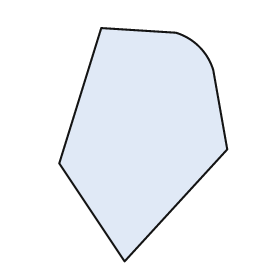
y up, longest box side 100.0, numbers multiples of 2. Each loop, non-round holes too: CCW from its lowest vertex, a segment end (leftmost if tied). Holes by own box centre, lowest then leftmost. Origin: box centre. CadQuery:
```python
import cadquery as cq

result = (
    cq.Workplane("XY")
    .moveTo(-8.0, -50.0)
    .lineTo(36.0, -2.0)
    .lineTo(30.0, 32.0)
    .threePointArc((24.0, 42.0), (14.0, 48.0))
    .lineTo(-18.0, 50.0)
    .lineTo(-36.0, -8.0)
    .close()
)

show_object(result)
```